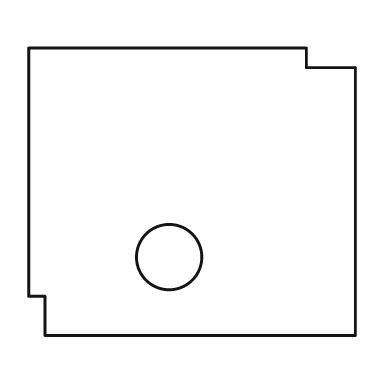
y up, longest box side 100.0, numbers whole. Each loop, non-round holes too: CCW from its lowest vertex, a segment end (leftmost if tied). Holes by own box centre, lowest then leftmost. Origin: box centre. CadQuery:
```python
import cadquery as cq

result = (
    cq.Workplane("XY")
    .moveTo(-45.0, -44.0)
    .lineTo(50.0, -44.0)
    .lineTo(50.0, 38.0)
    .lineTo(35.0, 38.0)
    .lineTo(35.0, 44.0)
    .lineTo(-50.0, 44.0)
    .lineTo(-50.0, -32.0)
    .lineTo(-45.0, -32.0)
    .close()
    .moveTo(-7.0, -20.0)
    .circle(10.0)
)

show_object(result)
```